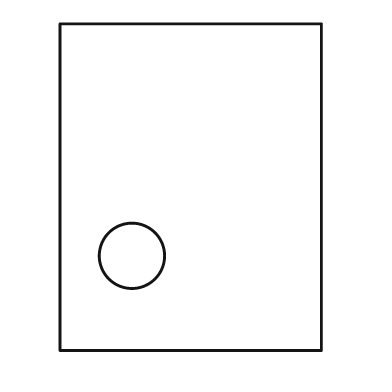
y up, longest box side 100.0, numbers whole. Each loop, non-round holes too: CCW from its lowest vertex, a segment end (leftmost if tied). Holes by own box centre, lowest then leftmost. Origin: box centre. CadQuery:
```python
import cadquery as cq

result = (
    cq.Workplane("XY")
    .moveTo(-40.0, -50.0)
    .lineTo(40.0, -50.0)
    .lineTo(40.0, 50.0)
    .lineTo(-40.0, 50.0)
    .close()
    .moveTo(-18.0, -21.0)
    .circle(10.0)
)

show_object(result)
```